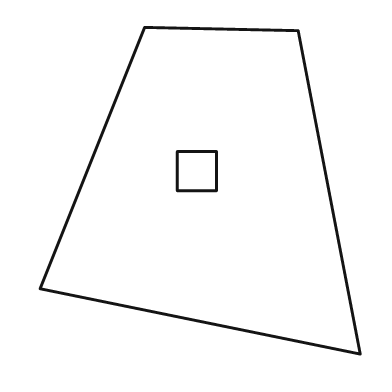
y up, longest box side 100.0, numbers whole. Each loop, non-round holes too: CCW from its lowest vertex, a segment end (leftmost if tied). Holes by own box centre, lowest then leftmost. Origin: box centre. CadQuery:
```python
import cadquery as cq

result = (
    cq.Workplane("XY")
    .moveTo(49.0, -50.0)
    .lineTo(30.0, 49.0)
    .lineTo(-17.0, 50.0)
    .lineTo(-49.0, -30.0)
    .close()
    .moveTo(-7.0, 0.0)
    .lineTo(5.0, 0.0)
    .lineTo(5.0, 12.0)
    .lineTo(-7.0, 12.0)
    .close()
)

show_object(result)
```